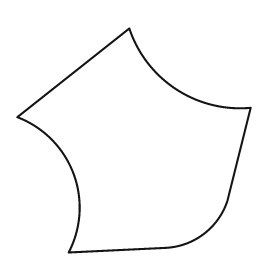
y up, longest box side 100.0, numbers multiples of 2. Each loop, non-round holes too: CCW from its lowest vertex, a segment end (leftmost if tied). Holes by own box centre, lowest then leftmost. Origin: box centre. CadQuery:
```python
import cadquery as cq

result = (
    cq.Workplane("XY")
    .moveTo(-28.0, -48.0)
    .lineTo(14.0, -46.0)
    .threePointArc((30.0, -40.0), (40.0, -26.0))
    .lineTo(50.0, 14.0)
    .threePointArc((18.0, 22.0), (-2.0, 48.0))
    .lineTo(-50.0, 10.0)
    .threePointArc((-26.0, -14.0), (-28.0, -48.0))
    .close()
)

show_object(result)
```